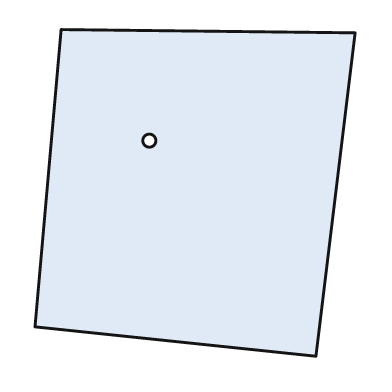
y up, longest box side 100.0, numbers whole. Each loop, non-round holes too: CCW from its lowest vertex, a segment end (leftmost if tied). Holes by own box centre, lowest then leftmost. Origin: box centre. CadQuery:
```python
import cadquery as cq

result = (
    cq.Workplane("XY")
    .moveTo(37.0, -50.0)
    .lineTo(49.0, 49.0)
    .lineTo(-41.0, 50.0)
    .lineTo(-49.0, -41.0)
    .close()
    .moveTo(-14.0, 16.0)
    .circle(2.0)
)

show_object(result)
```